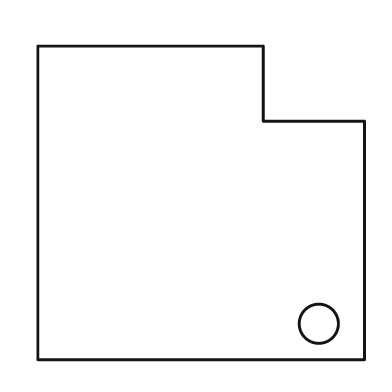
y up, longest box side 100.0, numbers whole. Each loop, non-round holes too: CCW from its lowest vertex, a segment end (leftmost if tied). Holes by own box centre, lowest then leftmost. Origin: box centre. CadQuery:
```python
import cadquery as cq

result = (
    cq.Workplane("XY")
    .moveTo(-50.0, -48.0)
    .lineTo(50.0, -48.0)
    .lineTo(50.0, 25.0)
    .lineTo(19.0, 25.0)
    .lineTo(19.0, 48.0)
    .lineTo(-50.0, 48.0)
    .close()
    .moveTo(36.0, -37.0)
    .circle(6.0)
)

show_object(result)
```